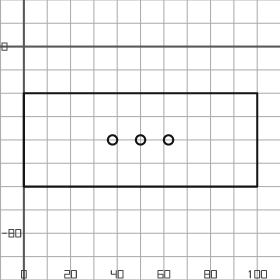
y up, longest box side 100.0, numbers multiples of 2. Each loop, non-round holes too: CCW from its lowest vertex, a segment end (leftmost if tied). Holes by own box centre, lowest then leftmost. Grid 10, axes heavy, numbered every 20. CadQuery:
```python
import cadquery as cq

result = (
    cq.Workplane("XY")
    .moveTo(0.0, -60.0)
    .lineTo(100.0, -60.0)
    .lineTo(100.0, -20.0)
    .lineTo(0.0, -20.0)
    .close()
    .moveTo(38.0, -40.0)
    .circle(2.0)
    .moveTo(50.0, -40.0)
    .circle(2.0)
    .moveTo(62.0, -40.0)
    .circle(2.0)
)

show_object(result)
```